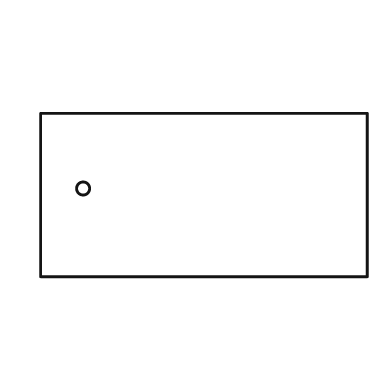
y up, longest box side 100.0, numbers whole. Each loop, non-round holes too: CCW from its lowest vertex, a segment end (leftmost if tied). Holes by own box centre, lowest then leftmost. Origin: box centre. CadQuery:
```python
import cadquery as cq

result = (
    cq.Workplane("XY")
    .moveTo(-50.0, -25.0)
    .lineTo(50.0, -25.0)
    .lineTo(50.0, 25.0)
    .lineTo(-50.0, 25.0)
    .close()
    .moveTo(-37.0, 2.0)
    .circle(2.0)
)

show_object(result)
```